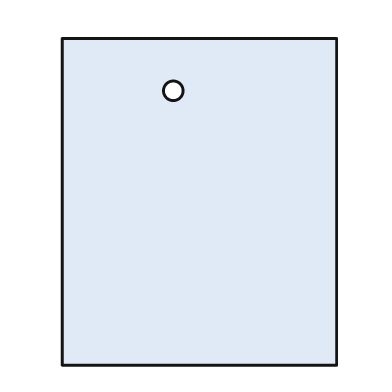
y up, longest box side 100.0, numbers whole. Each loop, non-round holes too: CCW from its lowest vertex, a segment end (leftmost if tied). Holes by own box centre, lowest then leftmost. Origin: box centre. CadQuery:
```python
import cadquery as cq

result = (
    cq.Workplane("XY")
    .moveTo(-42.0, -50.0)
    .lineTo(42.0, -50.0)
    .lineTo(42.0, 50.0)
    .lineTo(-42.0, 50.0)
    .close()
    .moveTo(-8.0, 34.0)
    .circle(3.0)
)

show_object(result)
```